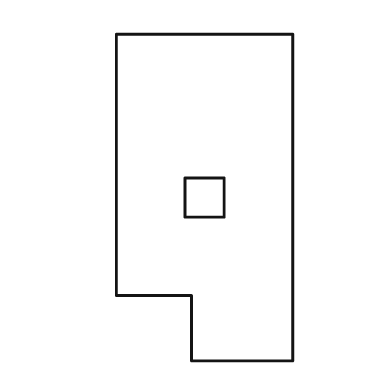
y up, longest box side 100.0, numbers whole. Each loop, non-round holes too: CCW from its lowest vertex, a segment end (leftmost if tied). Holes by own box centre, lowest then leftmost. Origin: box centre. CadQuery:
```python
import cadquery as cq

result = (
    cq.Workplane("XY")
    .moveTo(-4.0, -50.0)
    .lineTo(27.0, -50.0)
    .lineTo(27.0, 50.0)
    .lineTo(-27.0, 50.0)
    .lineTo(-27.0, -30.0)
    .lineTo(-4.0, -30.0)
    .close()
    .moveTo(-6.0, -6.0)
    .lineTo(6.0, -6.0)
    .lineTo(6.0, 6.0)
    .lineTo(-6.0, 6.0)
    .close()
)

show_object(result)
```